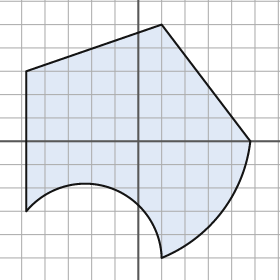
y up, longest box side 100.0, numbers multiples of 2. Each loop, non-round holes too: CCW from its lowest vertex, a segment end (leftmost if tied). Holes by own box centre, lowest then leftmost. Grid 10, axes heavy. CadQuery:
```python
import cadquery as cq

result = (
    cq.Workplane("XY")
    .moveTo(10.0, -50.0)
    .threePointArc((36.0, -30.0), (48.0, 0.0))
    .lineTo(10.0, 50.0)
    .lineTo(-48.0, 30.0)
    .lineTo(-48.0, -30.0)
    .threePointArc((-12.0, -20.0), (10.0, -50.0))
    .close()
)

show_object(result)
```